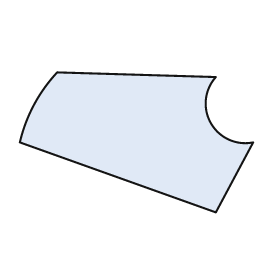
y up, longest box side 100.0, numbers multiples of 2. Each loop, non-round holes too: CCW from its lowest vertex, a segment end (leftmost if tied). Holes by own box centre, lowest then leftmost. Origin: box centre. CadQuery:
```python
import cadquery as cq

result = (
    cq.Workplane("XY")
    .moveTo(34.0, -30.0)
    .lineTo(50.0, 0.0)
    .threePointArc((32.0, 8.0), (34.0, 28.0))
    .lineTo(-34.0, 30.0)
    .threePointArc((-44.0, 16.0), (-50.0, 0.0))
    .close()
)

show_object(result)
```